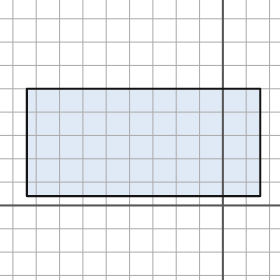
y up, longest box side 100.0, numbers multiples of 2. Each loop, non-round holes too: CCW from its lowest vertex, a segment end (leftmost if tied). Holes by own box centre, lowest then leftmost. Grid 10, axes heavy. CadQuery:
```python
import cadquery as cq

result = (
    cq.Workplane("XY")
    .moveTo(-84.0, 4.0)
    .lineTo(16.0, 4.0)
    .lineTo(16.0, 50.0)
    .lineTo(-84.0, 50.0)
    .close()
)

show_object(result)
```